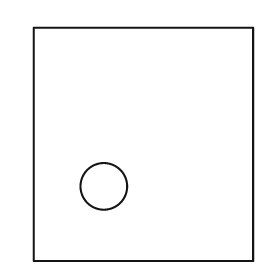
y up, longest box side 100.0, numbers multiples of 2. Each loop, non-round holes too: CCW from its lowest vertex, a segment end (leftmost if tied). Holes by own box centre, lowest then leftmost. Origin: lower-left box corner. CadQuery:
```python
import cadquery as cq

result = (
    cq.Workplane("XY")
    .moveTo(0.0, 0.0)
    .lineTo(94.0, 0.0)
    .lineTo(94.0, 100.0)
    .lineTo(0.0, 100.0)
    .close()
    .moveTo(30.0, 32.0)
    .circle(10.0)
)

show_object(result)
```